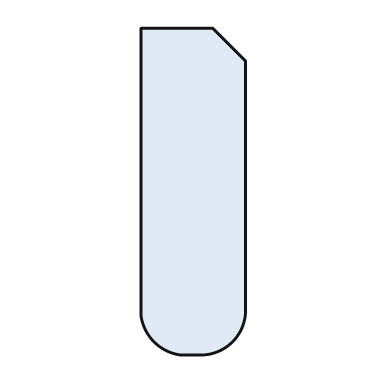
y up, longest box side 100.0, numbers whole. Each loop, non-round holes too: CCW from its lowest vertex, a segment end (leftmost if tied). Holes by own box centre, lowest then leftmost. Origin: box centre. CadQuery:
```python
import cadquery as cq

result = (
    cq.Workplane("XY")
    .moveTo(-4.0, -50.0)
    .lineTo(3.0, -50.0)
    .threePointArc((12.0, -46.0), (16.0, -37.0))
    .lineTo(16.0, 40.0)
    .lineTo(6.0, 50.0)
    .lineTo(-16.0, 50.0)
    .lineTo(-16.0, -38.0)
    .threePointArc((-12.0, -46.0), (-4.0, -50.0))
    .close()
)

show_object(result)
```